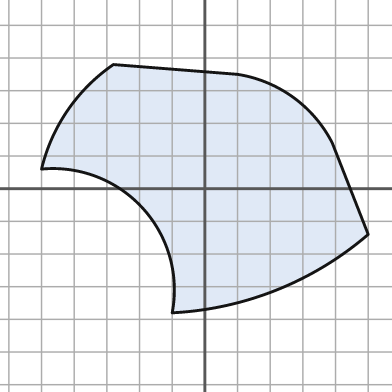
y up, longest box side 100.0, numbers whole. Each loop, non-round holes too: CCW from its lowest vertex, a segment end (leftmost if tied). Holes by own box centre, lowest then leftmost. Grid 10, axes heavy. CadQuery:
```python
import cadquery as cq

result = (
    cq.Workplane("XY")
    .moveTo(-10.0, -38.0)
    .threePointArc((22.0, -31.0), (50.0, -14.0))
    .lineTo(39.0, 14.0)
    .threePointArc((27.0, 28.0), (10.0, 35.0))
    .lineTo(-28.0, 38.0)
    .threePointArc((-42.0, 24.0), (-50.0, 6.0))
    .threePointArc((-19.0, -6.0), (-10.0, -38.0))
    .close()
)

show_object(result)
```